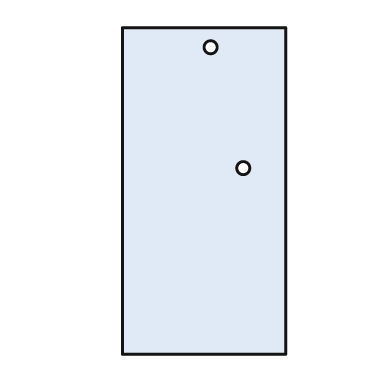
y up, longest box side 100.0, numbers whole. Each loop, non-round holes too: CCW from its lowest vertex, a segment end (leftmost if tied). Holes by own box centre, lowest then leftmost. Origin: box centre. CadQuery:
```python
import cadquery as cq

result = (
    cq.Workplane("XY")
    .moveTo(-25.0, -50.0)
    .lineTo(25.0, -50.0)
    .lineTo(25.0, 50.0)
    .lineTo(-25.0, 50.0)
    .close()
    .moveTo(12.0, 7.0)
    .circle(2.0)
    .moveTo(2.0, 44.0)
    .circle(2.0)
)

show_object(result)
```